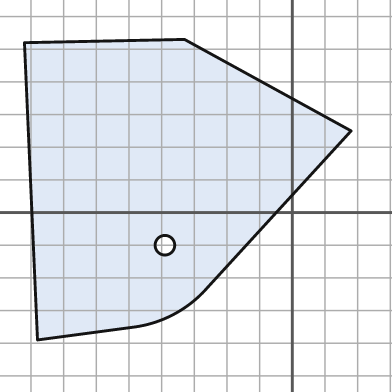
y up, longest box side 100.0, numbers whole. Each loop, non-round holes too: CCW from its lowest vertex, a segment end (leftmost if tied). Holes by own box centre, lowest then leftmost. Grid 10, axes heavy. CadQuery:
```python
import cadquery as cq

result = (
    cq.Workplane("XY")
    .moveTo(-78.0, -39.0)
    .lineTo(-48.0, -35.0)
    .threePointArc((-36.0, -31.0), (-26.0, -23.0))
    .lineTo(18.0, 25.0)
    .lineTo(-33.0, 53.0)
    .lineTo(-82.0, 52.0)
    .close()
    .moveTo(-39.0, -10.0)
    .circle(3.0)
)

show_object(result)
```